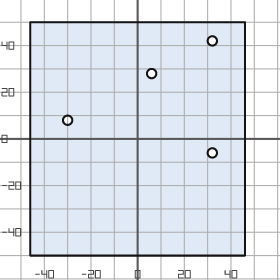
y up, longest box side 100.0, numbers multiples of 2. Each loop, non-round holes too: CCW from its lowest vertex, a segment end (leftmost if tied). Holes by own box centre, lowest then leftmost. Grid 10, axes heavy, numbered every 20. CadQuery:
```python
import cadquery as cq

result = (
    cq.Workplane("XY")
    .moveTo(-46.0, -50.0)
    .lineTo(46.0, -50.0)
    .lineTo(46.0, 50.0)
    .lineTo(-46.0, 50.0)
    .close()
    .moveTo(32.0, -6.0)
    .circle(2.0)
    .moveTo(-30.0, 8.0)
    .circle(2.0)
    .moveTo(6.0, 28.0)
    .circle(2.0)
    .moveTo(32.0, 42.0)
    .circle(2.0)
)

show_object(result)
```